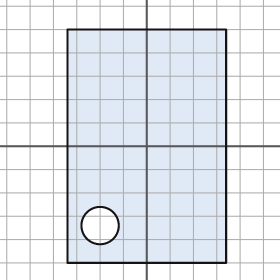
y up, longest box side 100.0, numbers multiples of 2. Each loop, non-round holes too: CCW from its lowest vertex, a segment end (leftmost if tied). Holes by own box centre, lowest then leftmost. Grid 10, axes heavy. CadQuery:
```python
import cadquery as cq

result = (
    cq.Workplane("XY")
    .moveTo(-34.0, -50.0)
    .lineTo(34.0, -50.0)
    .lineTo(34.0, 50.0)
    .lineTo(-34.0, 50.0)
    .close()
    .moveTo(-20.0, -34.0)
    .circle(8.0)
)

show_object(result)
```